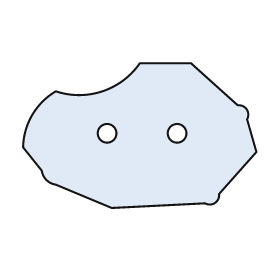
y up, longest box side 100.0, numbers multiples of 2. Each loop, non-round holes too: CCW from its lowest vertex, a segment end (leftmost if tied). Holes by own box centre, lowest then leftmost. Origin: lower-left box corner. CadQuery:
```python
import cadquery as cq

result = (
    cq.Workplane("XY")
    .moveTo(38.0, 0.0)
    .lineTo(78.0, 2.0)
    .threePointArc((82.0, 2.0), (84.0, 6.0))
    .lineTo(100.0, 24.0)
    .lineTo(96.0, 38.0)
    .threePointArc((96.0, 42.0), (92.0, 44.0))
    .lineTo(72.0, 62.0)
    .lineTo(50.0, 62.0)
    .threePointArc((34.0, 50.0), (14.0, 50.0))
    .threePointArc((4.0, 40.0), (0.0, 26.0))
    .lineTo(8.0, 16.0)
    .threePointArc((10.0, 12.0), (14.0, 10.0))
    .close()
    .moveTo(36.0, 32.0)
    .circle(4.0)
    .moveTo(66.0, 32.0)
    .circle(4.0)
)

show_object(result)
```